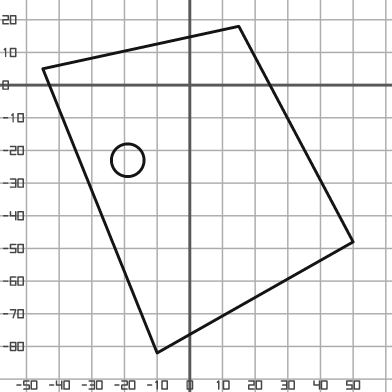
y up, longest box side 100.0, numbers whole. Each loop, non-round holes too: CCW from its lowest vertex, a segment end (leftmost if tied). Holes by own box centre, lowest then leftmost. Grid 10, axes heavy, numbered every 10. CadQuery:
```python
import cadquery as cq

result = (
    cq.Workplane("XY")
    .moveTo(-10.0, -82.0)
    .lineTo(50.0, -48.0)
    .lineTo(15.0, 18.0)
    .lineTo(-45.0, 5.0)
    .close()
    .moveTo(-19.0, -23.0)
    .circle(5.0)
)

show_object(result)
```